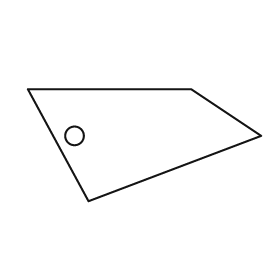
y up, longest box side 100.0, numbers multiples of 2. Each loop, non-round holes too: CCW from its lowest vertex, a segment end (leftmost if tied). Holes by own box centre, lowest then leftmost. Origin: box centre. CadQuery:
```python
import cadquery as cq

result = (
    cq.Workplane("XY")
    .moveTo(-24.0, -24.0)
    .lineTo(50.0, 4.0)
    .lineTo(20.0, 24.0)
    .lineTo(-50.0, 24.0)
    .close()
    .moveTo(-30.0, 4.0)
    .circle(4.0)
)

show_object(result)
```